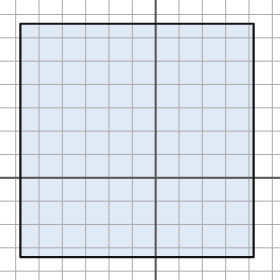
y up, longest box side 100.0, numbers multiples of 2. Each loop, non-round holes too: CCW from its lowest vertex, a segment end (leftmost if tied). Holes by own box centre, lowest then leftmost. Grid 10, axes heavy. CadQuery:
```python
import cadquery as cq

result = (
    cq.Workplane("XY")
    .moveTo(-58.0, -34.0)
    .lineTo(42.0, -34.0)
    .lineTo(42.0, 66.0)
    .lineTo(-58.0, 66.0)
    .close()
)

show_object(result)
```